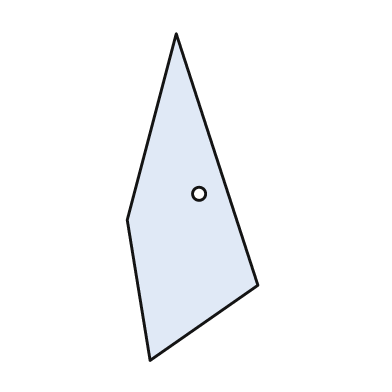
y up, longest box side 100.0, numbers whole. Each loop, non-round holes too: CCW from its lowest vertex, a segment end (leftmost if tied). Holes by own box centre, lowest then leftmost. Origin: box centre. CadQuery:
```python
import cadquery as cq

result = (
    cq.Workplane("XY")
    .moveTo(-13.0, -50.0)
    .lineTo(20.0, -27.0)
    .lineTo(-5.0, 50.0)
    .lineTo(-20.0, -7.0)
    .close()
    .moveTo(2.0, 1.0)
    .circle(2.0)
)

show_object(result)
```